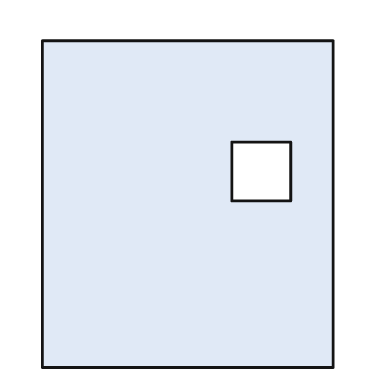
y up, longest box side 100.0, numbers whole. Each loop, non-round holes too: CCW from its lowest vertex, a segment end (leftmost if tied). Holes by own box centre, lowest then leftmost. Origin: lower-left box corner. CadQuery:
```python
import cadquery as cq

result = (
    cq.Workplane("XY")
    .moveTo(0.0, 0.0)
    .lineTo(89.0, 0.0)
    .lineTo(89.0, 100.0)
    .lineTo(0.0, 100.0)
    .close()
    .moveTo(58.0, 51.0)
    .lineTo(76.0, 51.0)
    .lineTo(76.0, 69.0)
    .lineTo(58.0, 69.0)
    .close()
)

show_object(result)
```